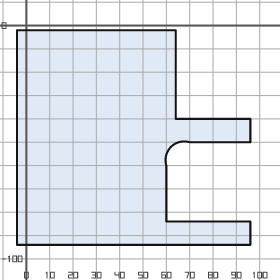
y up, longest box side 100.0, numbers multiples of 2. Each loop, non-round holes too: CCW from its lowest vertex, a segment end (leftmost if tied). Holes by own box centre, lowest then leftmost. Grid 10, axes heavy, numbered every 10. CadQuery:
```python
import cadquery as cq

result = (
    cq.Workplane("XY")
    .moveTo(-4.0, -94.0)
    .lineTo(96.0, -94.0)
    .lineTo(96.0, -84.0)
    .lineTo(60.0, -84.0)
    .lineTo(60.0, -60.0)
    .threePointArc((62.0, -52.0), (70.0, -50.0))
    .lineTo(96.0, -50.0)
    .lineTo(96.0, -40.0)
    .lineTo(64.0, -40.0)
    .lineTo(64.0, -2.0)
    .lineTo(-4.0, -2.0)
    .close()
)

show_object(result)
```